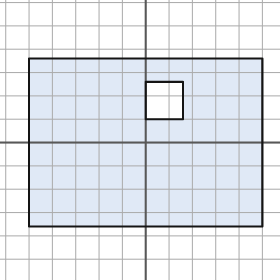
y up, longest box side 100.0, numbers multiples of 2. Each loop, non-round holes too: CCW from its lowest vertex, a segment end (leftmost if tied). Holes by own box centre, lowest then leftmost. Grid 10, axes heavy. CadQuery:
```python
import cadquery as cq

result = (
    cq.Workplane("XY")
    .moveTo(-50.0, -36.0)
    .lineTo(50.0, -36.0)
    .lineTo(50.0, 36.0)
    .lineTo(-50.0, 36.0)
    .close()
    .moveTo(0.0, 10.0)
    .lineTo(16.0, 10.0)
    .lineTo(16.0, 26.0)
    .lineTo(0.0, 26.0)
    .close()
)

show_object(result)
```